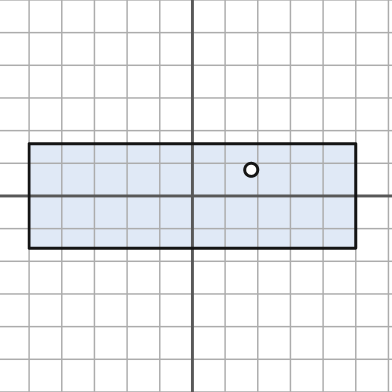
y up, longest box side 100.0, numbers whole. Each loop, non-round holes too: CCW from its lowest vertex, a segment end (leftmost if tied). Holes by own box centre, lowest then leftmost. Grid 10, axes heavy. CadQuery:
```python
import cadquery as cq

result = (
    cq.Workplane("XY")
    .moveTo(-50.0, -16.0)
    .lineTo(50.0, -16.0)
    .lineTo(50.0, 16.0)
    .lineTo(-50.0, 16.0)
    .close()
    .moveTo(18.0, 8.0)
    .circle(2.0)
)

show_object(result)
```